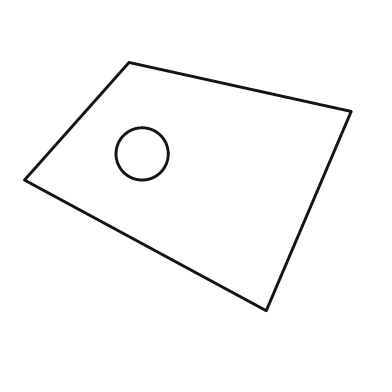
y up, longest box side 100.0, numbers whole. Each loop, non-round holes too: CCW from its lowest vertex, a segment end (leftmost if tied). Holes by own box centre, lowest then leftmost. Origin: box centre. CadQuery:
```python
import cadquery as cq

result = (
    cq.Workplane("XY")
    .moveTo(24.0, -38.0)
    .lineTo(50.0, 23.0)
    .lineTo(-18.0, 38.0)
    .lineTo(-50.0, 2.0)
    .close()
    .moveTo(-14.0, 10.0)
    .circle(8.0)
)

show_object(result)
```